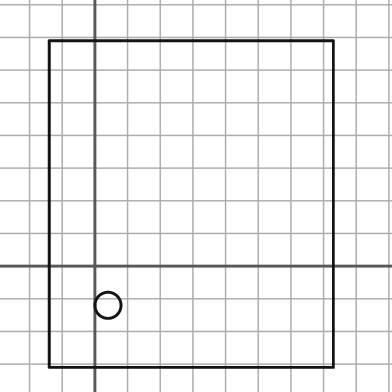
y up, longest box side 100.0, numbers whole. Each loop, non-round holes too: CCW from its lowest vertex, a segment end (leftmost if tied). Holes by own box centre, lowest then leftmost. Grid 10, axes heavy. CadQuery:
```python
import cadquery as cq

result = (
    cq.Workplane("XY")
    .moveTo(-14.0, -31.0)
    .lineTo(73.0, -31.0)
    .lineTo(73.0, 69.0)
    .lineTo(-14.0, 69.0)
    .close()
    .moveTo(4.0, -12.0)
    .circle(4.0)
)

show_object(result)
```